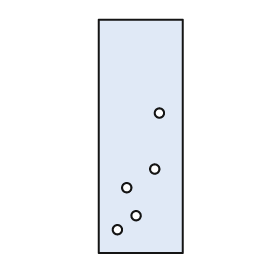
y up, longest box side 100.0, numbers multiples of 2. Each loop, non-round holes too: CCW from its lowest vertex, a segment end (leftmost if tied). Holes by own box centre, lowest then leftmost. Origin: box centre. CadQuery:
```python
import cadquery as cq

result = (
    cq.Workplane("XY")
    .moveTo(-18.0, -50.0)
    .lineTo(18.0, -50.0)
    .lineTo(18.0, 50.0)
    .lineTo(-18.0, 50.0)
    .close()
    .moveTo(-10.0, -40.0)
    .circle(2.0)
    .moveTo(-2.0, -34.0)
    .circle(2.0)
    .moveTo(-6.0, -22.0)
    .circle(2.0)
    .moveTo(6.0, -14.0)
    .circle(2.0)
    .moveTo(8.0, 10.0)
    .circle(2.0)
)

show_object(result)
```